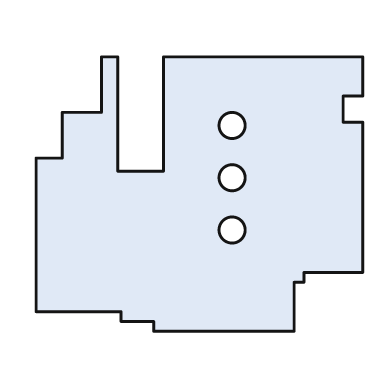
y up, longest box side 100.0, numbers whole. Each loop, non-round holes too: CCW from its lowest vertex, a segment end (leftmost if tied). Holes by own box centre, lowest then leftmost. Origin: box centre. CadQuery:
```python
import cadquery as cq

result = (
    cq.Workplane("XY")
    .moveTo(-14.0, -42.0)
    .lineTo(29.0, -42.0)
    .lineTo(29.0, -27.0)
    .lineTo(32.0, -27.0)
    .lineTo(32.0, -24.0)
    .lineTo(50.0, -24.0)
    .lineTo(50.0, 22.0)
    .lineTo(44.0, 22.0)
    .lineTo(44.0, 30.0)
    .lineTo(50.0, 30.0)
    .lineTo(50.0, 42.0)
    .lineTo(-11.0, 42.0)
    .lineTo(-11.0, 7.0)
    .lineTo(-25.0, 7.0)
    .lineTo(-25.0, 42.0)
    .lineTo(-30.0, 42.0)
    .lineTo(-30.0, 25.0)
    .lineTo(-42.0, 25.0)
    .lineTo(-42.0, 11.0)
    .lineTo(-50.0, 11.0)
    .lineTo(-50.0, -36.0)
    .lineTo(-24.0, -36.0)
    .lineTo(-24.0, -39.0)
    .lineTo(-14.0, -39.0)
    .close()
    .moveTo(10.0, -11.0)
    .circle(4.0)
    .moveTo(10.0, 5.0)
    .circle(4.0)
    .moveTo(10.0, 21.0)
    .circle(4.0)
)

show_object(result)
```